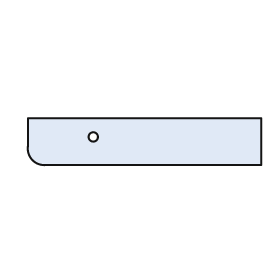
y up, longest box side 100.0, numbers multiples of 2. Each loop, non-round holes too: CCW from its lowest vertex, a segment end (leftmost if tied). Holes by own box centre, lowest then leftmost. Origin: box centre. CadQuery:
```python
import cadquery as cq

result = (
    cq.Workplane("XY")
    .moveTo(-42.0, -10.0)
    .lineTo(50.0, -10.0)
    .lineTo(50.0, 10.0)
    .lineTo(-50.0, 10.0)
    .lineTo(-50.0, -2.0)
    .threePointArc((-48.0, -8.0), (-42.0, -10.0))
    .close()
    .moveTo(-22.0, 2.0)
    .circle(2.0)
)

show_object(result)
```